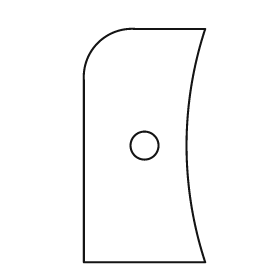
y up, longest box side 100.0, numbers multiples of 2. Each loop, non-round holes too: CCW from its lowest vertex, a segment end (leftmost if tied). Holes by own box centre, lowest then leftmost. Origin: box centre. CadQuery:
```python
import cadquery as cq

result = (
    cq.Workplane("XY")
    .moveTo(-26.0, -50.0)
    .lineTo(26.0, -50.0)
    .threePointArc((18.0, 0.0), (26.0, 50.0))
    .lineTo(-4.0, 50.0)
    .threePointArc((-20.0, 44.0), (-26.0, 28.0))
    .close()
    .moveTo(0.0, 0.0)
    .circle(6.0)
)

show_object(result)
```